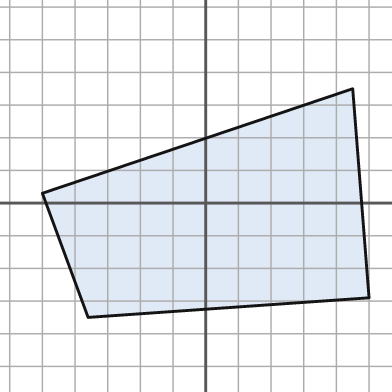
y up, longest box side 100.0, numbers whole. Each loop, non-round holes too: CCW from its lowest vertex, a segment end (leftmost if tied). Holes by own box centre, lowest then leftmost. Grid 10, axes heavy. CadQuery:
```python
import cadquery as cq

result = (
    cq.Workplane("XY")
    .moveTo(-36.0, -35.0)
    .lineTo(50.0, -29.0)
    .lineTo(45.0, 35.0)
    .lineTo(-50.0, 3.0)
    .close()
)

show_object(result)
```